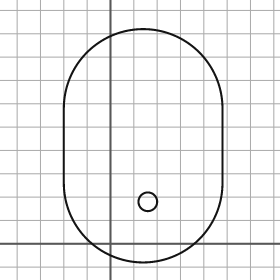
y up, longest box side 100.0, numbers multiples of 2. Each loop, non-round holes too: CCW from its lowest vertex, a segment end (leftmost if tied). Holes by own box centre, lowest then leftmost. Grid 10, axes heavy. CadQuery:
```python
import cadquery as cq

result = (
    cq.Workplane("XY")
    .moveTo(-20.0, 26.0)
    .threePointArc((14.0, -8.0), (48.0, 26.0))
    .lineTo(48.0, 58.0)
    .threePointArc((14.0, 92.0), (-20.0, 58.0))
    .close()
    .moveTo(16.0, 18.0)
    .circle(4.0)
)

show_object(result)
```